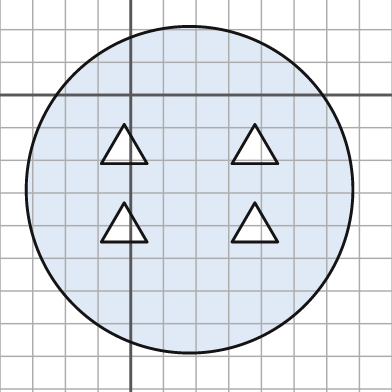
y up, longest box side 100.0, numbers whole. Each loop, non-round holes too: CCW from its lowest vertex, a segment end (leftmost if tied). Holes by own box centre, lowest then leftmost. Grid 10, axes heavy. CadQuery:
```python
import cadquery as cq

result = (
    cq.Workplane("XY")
    .moveTo(18.0, -29.0)
    .circle(50.0)
    .moveTo(-9.0, -45.0)
    .lineTo(5.0, -45.0)
    .lineTo(-2.0, -33.0)
    .close()
    .moveTo(31.0, -45.0)
    .lineTo(45.0, -45.0)
    .lineTo(38.0, -33.0)
    .close()
    .moveTo(-9.0, -21.0)
    .lineTo(5.0, -21.0)
    .lineTo(-2.0, -9.0)
    .close()
    .moveTo(31.0, -21.0)
    .lineTo(45.0, -21.0)
    .lineTo(38.0, -9.0)
    .close()
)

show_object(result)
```